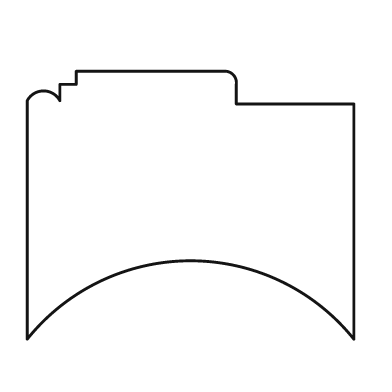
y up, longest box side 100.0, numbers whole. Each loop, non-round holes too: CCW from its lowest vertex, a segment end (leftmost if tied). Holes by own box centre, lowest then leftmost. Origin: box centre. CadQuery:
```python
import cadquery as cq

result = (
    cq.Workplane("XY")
    .moveTo(-50.0, -41.0)
    .threePointArc((0.0, -17.0), (50.0, -41.0))
    .lineTo(50.0, 31.0)
    .lineTo(14.0, 31.0)
    .lineTo(14.0, 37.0)
    .threePointArc((13.0, 40.0), (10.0, 41.0))
    .lineTo(-35.0, 41.0)
    .lineTo(-35.0, 37.0)
    .lineTo(-40.0, 37.0)
    .lineTo(-40.0, 32.0)
    .threePointArc((-45.0, 35.0), (-50.0, 32.0))
    .close()
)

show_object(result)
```